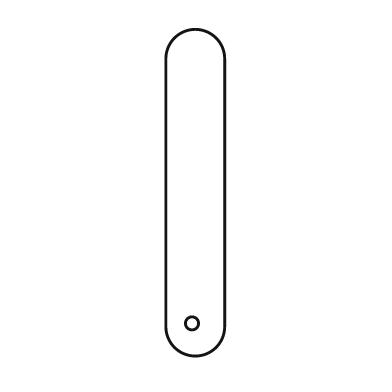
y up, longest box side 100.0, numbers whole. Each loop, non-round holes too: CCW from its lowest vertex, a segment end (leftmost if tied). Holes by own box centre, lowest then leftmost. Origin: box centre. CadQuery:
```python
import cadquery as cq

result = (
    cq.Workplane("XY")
    .moveTo(-9.0, -41.0)
    .threePointArc((0.0, -50.0), (9.0, -41.0))
    .lineTo(9.0, 41.0)
    .threePointArc((0.0, 50.0), (-9.0, 41.0))
    .close()
    .moveTo(-1.0, -40.0)
    .circle(2.0)
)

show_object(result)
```